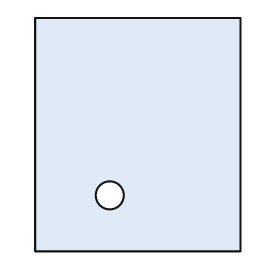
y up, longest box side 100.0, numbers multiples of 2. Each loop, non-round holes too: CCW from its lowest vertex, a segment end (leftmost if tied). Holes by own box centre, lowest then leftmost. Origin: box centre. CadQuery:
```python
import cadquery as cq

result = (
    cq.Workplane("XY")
    .moveTo(-44.0, -50.0)
    .lineTo(44.0, -50.0)
    .lineTo(44.0, 50.0)
    .lineTo(-44.0, 50.0)
    .close()
    .moveTo(-12.0, -26.0)
    .circle(6.0)
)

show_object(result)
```